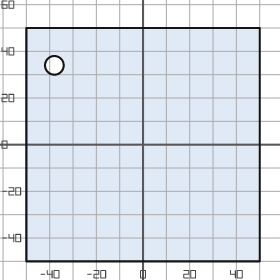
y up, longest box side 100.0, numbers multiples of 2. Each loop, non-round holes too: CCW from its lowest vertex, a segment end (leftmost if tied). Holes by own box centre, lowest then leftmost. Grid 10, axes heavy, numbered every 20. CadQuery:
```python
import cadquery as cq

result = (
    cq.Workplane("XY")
    .moveTo(-50.0, -50.0)
    .lineTo(50.0, -50.0)
    .lineTo(50.0, 50.0)
    .lineTo(-50.0, 50.0)
    .close()
    .moveTo(-38.0, 34.0)
    .circle(4.0)
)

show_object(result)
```